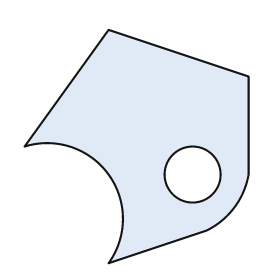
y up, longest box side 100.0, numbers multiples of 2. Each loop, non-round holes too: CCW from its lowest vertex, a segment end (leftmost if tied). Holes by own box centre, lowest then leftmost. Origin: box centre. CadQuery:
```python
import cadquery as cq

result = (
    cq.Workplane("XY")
    .moveTo(-12.0, -50.0)
    .lineTo(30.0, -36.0)
    .threePointArc((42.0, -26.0), (48.0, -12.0))
    .lineTo(48.0, 30.0)
    .lineTo(-12.0, 50.0)
    .lineTo(-48.0, 0.0)
    .threePointArc((-12.0, -12.0), (-12.0, -50.0))
    .close()
    .moveTo(24.0, -12.0)
    .circle(12.0)
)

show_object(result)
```